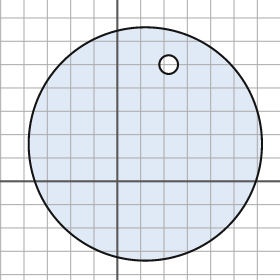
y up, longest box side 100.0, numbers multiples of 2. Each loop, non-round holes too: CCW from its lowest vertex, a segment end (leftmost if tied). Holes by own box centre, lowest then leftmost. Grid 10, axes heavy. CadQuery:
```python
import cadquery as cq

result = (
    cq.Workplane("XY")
    .moveTo(12.0, 16.0)
    .circle(50.0)
    .moveTo(22.0, 50.0)
    .circle(4.0)
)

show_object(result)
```